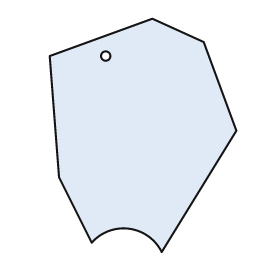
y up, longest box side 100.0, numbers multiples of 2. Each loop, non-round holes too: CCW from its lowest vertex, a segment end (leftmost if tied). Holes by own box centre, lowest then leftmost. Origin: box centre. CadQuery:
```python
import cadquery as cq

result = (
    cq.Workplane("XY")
    .moveTo(8.0, -50.0)
    .lineTo(40.0, 2.0)
    .lineTo(26.0, 40.0)
    .lineTo(4.0, 50.0)
    .lineTo(-40.0, 34.0)
    .lineTo(-36.0, -18.0)
    .lineTo(-22.0, -46.0)
    .threePointArc((-6.0, -40.0), (8.0, -50.0))
    .close()
    .moveTo(-16.0, 34.0)
    .circle(2.0)
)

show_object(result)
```